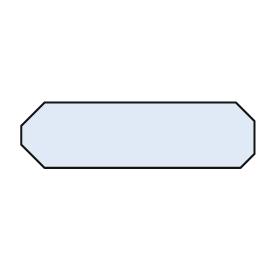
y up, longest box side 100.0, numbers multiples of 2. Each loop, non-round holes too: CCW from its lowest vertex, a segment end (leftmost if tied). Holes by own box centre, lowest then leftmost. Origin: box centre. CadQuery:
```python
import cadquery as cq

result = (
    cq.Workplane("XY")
    .moveTo(-40.0, -14.0)
    .lineTo(44.0, -14.0)
    .lineTo(50.0, -8.0)
    .lineTo(50.0, 6.0)
    .lineTo(42.0, 14.0)
    .lineTo(-40.0, 14.0)
    .lineTo(-50.0, 4.0)
    .lineTo(-50.0, -4.0)
    .close()
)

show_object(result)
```